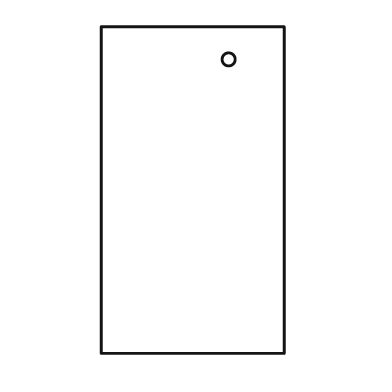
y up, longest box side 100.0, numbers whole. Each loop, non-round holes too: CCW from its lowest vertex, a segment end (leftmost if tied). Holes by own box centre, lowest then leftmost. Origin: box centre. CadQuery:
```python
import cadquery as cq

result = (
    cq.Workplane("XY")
    .moveTo(-28.0, -50.0)
    .lineTo(28.0, -50.0)
    .lineTo(28.0, 50.0)
    .lineTo(-28.0, 50.0)
    .close()
    .moveTo(11.0, 40.0)
    .circle(2.0)
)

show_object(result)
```